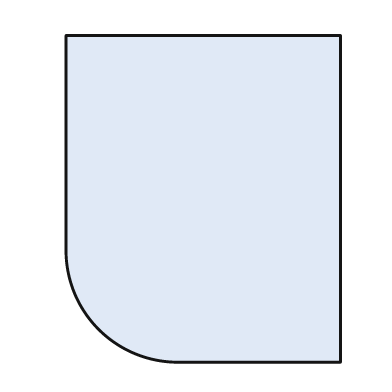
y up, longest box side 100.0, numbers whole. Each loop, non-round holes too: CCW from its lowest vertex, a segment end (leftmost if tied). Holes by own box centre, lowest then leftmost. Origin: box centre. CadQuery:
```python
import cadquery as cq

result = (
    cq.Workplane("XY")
    .moveTo(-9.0, -50.0)
    .lineTo(42.0, -50.0)
    .lineTo(42.0, 50.0)
    .lineTo(-42.0, 50.0)
    .lineTo(-42.0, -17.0)
    .threePointArc((-32.0, -40.0), (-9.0, -50.0))
    .close()
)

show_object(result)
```